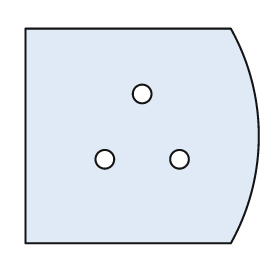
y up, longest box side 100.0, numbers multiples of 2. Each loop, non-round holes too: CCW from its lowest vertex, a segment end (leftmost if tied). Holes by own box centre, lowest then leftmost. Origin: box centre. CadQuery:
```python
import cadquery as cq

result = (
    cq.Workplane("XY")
    .moveTo(-50.0, -46.0)
    .lineTo(38.0, -46.0)
    .threePointArc((50.0, 0.0), (38.0, 46.0))
    .lineTo(-50.0, 46.0)
    .close()
    .moveTo(-16.0, -10.0)
    .circle(4.0)
    .moveTo(16.0, -10.0)
    .circle(4.0)
    .moveTo(0.0, 18.0)
    .circle(4.0)
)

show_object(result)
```